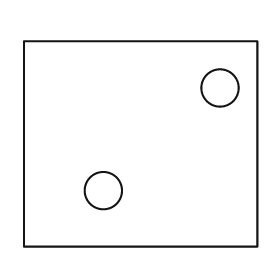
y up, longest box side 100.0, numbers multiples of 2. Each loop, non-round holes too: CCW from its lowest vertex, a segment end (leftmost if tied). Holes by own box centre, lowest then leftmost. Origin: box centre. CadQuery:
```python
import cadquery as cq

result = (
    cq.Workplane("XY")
    .moveTo(-50.0, -44.0)
    .lineTo(50.0, -44.0)
    .lineTo(50.0, 44.0)
    .lineTo(-50.0, 44.0)
    .close()
    .moveTo(-16.0, -20.0)
    .circle(8.0)
    .moveTo(34.0, 24.0)
    .circle(8.0)
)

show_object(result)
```